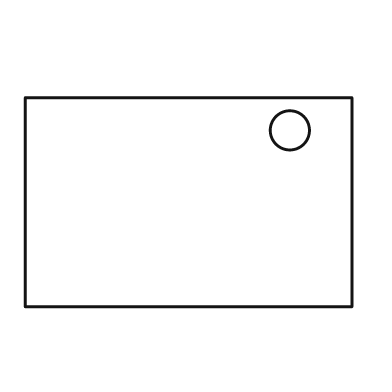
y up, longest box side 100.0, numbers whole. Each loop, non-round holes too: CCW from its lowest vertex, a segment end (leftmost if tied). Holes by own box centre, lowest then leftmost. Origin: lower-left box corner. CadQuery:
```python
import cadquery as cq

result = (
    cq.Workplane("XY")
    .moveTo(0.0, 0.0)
    .lineTo(100.0, 0.0)
    .lineTo(100.0, 64.0)
    .lineTo(0.0, 64.0)
    .close()
    .moveTo(81.0, 54.0)
    .circle(6.0)
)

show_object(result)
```